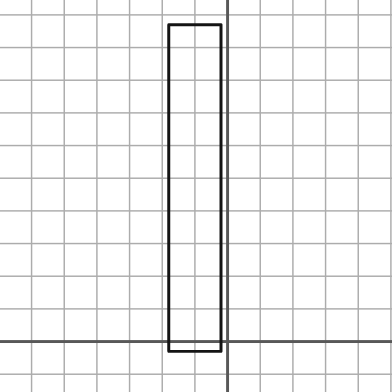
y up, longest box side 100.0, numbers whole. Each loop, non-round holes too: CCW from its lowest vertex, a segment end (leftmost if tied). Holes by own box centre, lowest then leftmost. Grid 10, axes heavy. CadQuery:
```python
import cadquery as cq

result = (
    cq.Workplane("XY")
    .moveTo(-18.0, -3.0)
    .lineTo(-2.0, -3.0)
    .lineTo(-2.0, 97.0)
    .lineTo(-18.0, 97.0)
    .close()
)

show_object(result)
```